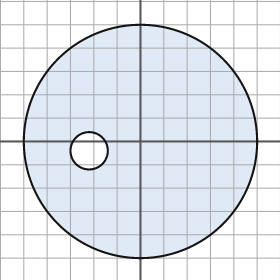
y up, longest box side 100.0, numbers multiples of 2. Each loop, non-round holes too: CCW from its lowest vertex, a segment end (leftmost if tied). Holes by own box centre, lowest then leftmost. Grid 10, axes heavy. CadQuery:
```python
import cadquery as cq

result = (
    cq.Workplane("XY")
    .moveTo(0.0, 0.0)
    .circle(50.0)
    .moveTo(-22.0, -4.0)
    .circle(8.0)
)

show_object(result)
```